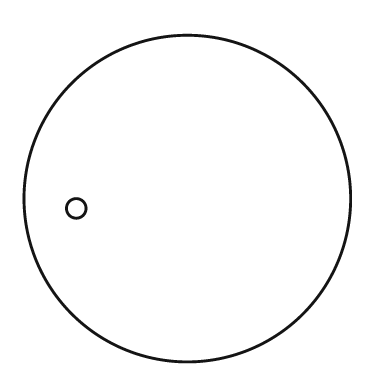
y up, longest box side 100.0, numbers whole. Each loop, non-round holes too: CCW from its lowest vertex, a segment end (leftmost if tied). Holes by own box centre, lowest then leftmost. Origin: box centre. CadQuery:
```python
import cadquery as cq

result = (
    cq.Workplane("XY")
    .moveTo(0.0, 0.0)
    .circle(50.0)
    .moveTo(-34.0, -3.0)
    .circle(3.0)
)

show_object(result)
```